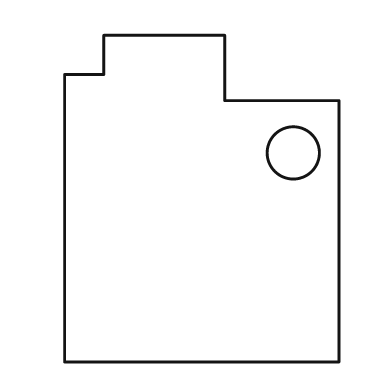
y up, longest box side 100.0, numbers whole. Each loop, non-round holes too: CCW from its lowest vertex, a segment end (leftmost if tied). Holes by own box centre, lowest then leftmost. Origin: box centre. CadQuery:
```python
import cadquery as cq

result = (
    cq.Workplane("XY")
    .moveTo(-42.0, -50.0)
    .lineTo(42.0, -50.0)
    .lineTo(42.0, 30.0)
    .lineTo(7.0, 30.0)
    .lineTo(7.0, 50.0)
    .lineTo(-30.0, 50.0)
    .lineTo(-30.0, 38.0)
    .lineTo(-42.0, 38.0)
    .close()
    .moveTo(28.0, 14.0)
    .circle(8.0)
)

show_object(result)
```